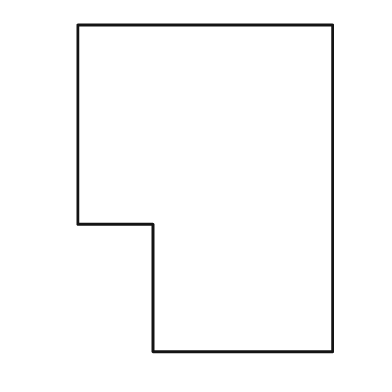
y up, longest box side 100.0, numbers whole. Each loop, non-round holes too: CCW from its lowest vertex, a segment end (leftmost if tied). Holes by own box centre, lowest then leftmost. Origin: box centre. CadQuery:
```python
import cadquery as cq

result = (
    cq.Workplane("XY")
    .moveTo(-16.0, -50.0)
    .lineTo(39.0, -50.0)
    .lineTo(39.0, 50.0)
    .lineTo(-39.0, 50.0)
    .lineTo(-39.0, -11.0)
    .lineTo(-16.0, -11.0)
    .close()
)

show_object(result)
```